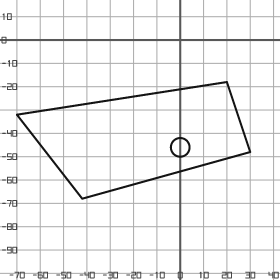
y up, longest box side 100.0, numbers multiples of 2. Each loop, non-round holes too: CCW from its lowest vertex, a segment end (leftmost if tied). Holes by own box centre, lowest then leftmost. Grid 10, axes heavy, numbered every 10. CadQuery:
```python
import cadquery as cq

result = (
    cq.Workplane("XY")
    .moveTo(-42.0, -68.0)
    .lineTo(30.0, -48.0)
    .lineTo(20.0, -18.0)
    .lineTo(-70.0, -32.0)
    .close()
    .moveTo(0.0, -46.0)
    .circle(4.0)
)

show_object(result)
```